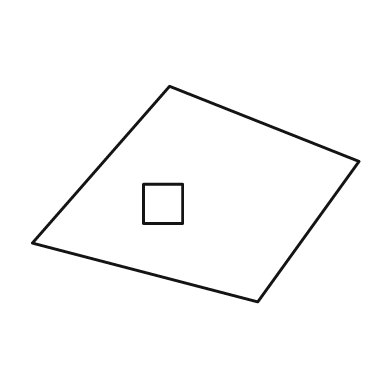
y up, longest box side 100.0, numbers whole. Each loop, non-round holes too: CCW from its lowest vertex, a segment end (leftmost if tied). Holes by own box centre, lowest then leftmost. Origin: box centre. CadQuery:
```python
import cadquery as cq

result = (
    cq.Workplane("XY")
    .moveTo(19.0, -33.0)
    .lineTo(50.0, 10.0)
    .lineTo(-8.0, 33.0)
    .lineTo(-50.0, -15.0)
    .close()
    .moveTo(-16.0, -9.0)
    .lineTo(-4.0, -9.0)
    .lineTo(-4.0, 3.0)
    .lineTo(-16.0, 3.0)
    .close()
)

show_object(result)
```